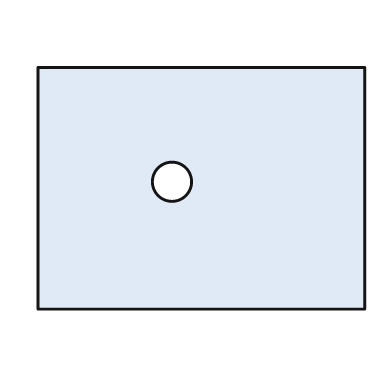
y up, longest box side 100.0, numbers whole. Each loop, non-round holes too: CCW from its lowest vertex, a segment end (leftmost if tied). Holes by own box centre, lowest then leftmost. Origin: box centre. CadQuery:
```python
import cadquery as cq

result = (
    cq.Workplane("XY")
    .moveTo(-50.0, -37.0)
    .lineTo(50.0, -37.0)
    .lineTo(50.0, 37.0)
    .lineTo(-50.0, 37.0)
    .close()
    .moveTo(-9.0, 2.0)
    .circle(6.0)
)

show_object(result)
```